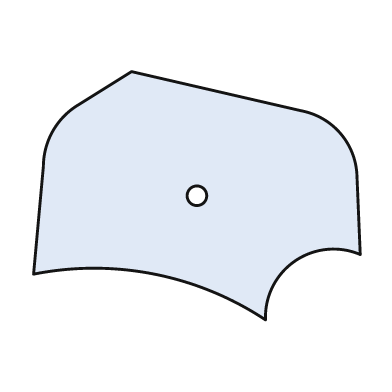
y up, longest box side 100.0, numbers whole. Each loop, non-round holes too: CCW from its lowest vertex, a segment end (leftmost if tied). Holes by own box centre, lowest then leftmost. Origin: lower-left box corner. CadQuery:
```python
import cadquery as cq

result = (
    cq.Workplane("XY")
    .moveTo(71.0, 0.0)
    .threePointArc((80.0, 18.0), (100.0, 20.0))
    .lineTo(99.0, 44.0)
    .threePointArc((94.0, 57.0), (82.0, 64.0))
    .lineTo(30.0, 76.0)
    .lineTo(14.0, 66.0)
    .threePointArc((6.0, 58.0), (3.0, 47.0))
    .lineTo(0.0, 14.0)
    .threePointArc((37.0, 14.0), (71.0, 0.0))
    .close()
    .moveTo(50.0, 38.0)
    .circle(3.0)
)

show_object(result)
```